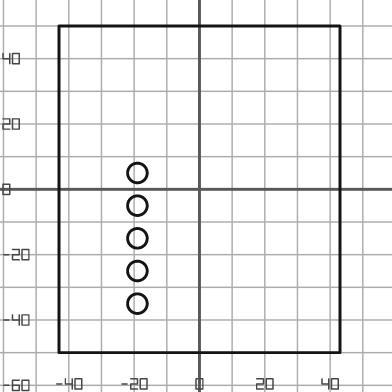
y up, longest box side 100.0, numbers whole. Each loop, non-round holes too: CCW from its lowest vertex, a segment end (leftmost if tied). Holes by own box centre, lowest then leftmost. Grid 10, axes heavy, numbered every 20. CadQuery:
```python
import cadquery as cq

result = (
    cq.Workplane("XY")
    .moveTo(-43.0, -50.0)
    .lineTo(43.0, -50.0)
    .lineTo(43.0, 50.0)
    .lineTo(-43.0, 50.0)
    .close()
    .moveTo(-19.0, -35.0)
    .circle(3.0)
    .moveTo(-19.0, -25.0)
    .circle(3.0)
    .moveTo(-19.0, -15.0)
    .circle(3.0)
    .moveTo(-19.0, -5.0)
    .circle(3.0)
    .moveTo(-19.0, 5.0)
    .circle(3.0)
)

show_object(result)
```